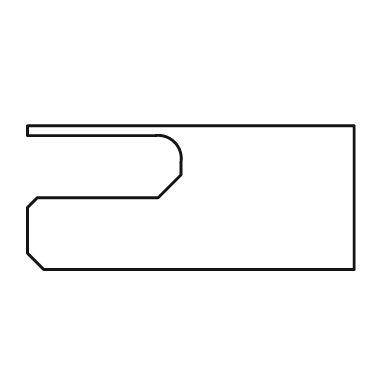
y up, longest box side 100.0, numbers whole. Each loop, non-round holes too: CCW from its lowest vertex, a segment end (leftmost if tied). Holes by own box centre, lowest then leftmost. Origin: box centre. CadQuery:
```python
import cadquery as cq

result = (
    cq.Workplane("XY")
    .moveTo(-45.0, -22.0)
    .lineTo(50.0, -22.0)
    .lineTo(50.0, 22.0)
    .lineTo(-50.0, 22.0)
    .lineTo(-50.0, 19.0)
    .lineTo(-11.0, 19.0)
    .threePointArc((-5.0, 17.0), (-3.0, 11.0))
    .lineTo(-3.0, 7.0)
    .lineTo(-10.0, 0.0)
    .lineTo(-47.0, 0.0)
    .lineTo(-50.0, -3.0)
    .lineTo(-50.0, -17.0)
    .close()
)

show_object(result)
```